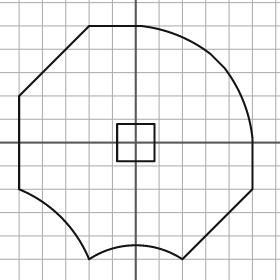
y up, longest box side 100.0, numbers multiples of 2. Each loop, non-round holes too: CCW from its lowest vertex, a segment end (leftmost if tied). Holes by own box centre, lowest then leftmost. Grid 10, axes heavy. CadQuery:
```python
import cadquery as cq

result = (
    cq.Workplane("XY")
    .moveTo(-20.0, -50.0)
    .threePointArc((0.0, -44.0), (20.0, -50.0))
    .lineTo(50.0, -20.0)
    .lineTo(50.0, 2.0)
    .threePointArc((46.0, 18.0), (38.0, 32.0))
    .lineTo(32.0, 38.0)
    .threePointArc((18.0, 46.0), (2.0, 50.0))
    .lineTo(-20.0, 50.0)
    .lineTo(-50.0, 20.0)
    .lineTo(-50.0, -20.0)
    .threePointArc((-32.0, -32.0), (-20.0, -50.0))
    .close()
    .moveTo(-8.0, -8.0)
    .lineTo(8.0, -8.0)
    .lineTo(8.0, 8.0)
    .lineTo(-8.0, 8.0)
    .close()
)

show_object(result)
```